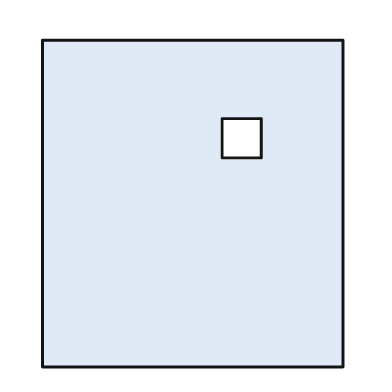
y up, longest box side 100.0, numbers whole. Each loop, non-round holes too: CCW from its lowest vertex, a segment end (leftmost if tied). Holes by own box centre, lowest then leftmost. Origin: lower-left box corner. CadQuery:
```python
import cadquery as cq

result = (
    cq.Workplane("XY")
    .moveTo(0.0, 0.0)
    .lineTo(92.0, 0.0)
    .lineTo(92.0, 100.0)
    .lineTo(0.0, 100.0)
    .close()
    .moveTo(55.0, 64.0)
    .lineTo(67.0, 64.0)
    .lineTo(67.0, 76.0)
    .lineTo(55.0, 76.0)
    .close()
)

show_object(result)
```